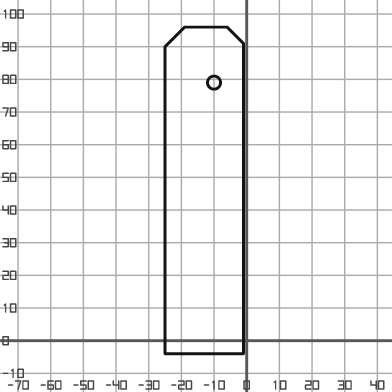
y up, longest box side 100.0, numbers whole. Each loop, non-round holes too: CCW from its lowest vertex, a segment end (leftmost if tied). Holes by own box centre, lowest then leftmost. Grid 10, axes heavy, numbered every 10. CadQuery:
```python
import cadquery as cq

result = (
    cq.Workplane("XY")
    .moveTo(-25.0, -4.0)
    .lineTo(-1.0, -4.0)
    .lineTo(-1.0, 91.0)
    .lineTo(-6.0, 96.0)
    .lineTo(-19.0, 96.0)
    .lineTo(-25.0, 90.0)
    .close()
    .moveTo(-10.0, 79.0)
    .circle(2.0)
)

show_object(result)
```